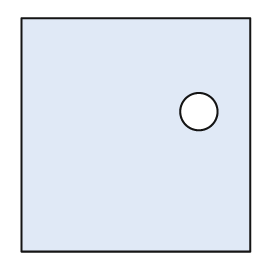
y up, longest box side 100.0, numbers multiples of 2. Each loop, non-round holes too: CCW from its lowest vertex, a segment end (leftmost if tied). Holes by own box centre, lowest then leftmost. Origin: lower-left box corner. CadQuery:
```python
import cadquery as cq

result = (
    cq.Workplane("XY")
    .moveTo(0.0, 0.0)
    .lineTo(98.0, 0.0)
    .lineTo(98.0, 100.0)
    .lineTo(0.0, 100.0)
    .close()
    .moveTo(76.0, 60.0)
    .circle(8.0)
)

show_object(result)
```